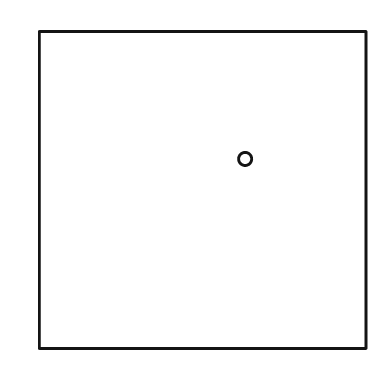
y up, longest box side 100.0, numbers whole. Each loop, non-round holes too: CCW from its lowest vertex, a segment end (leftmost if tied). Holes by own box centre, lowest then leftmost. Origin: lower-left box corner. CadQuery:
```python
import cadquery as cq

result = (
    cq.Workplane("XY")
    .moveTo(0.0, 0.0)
    .lineTo(100.0, 0.0)
    .lineTo(100.0, 97.0)
    .lineTo(0.0, 97.0)
    .close()
    .moveTo(63.0, 58.0)
    .circle(2.0)
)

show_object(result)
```